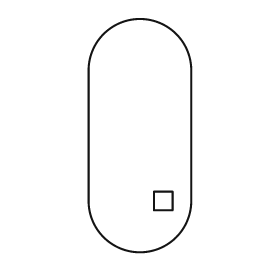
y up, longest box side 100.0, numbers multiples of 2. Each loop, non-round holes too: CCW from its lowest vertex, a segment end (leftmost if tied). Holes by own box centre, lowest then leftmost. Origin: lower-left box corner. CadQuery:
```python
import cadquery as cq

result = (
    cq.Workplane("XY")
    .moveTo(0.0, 22.0)
    .threePointArc((22.0, 0.0), (44.0, 22.0))
    .lineTo(44.0, 78.0)
    .threePointArc((22.0, 100.0), (0.0, 78.0))
    .close()
    .moveTo(28.0, 18.0)
    .lineTo(36.0, 18.0)
    .lineTo(36.0, 26.0)
    .lineTo(28.0, 26.0)
    .close()
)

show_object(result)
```